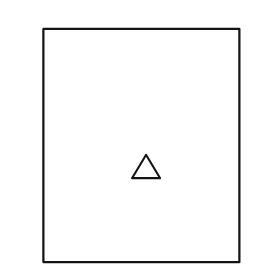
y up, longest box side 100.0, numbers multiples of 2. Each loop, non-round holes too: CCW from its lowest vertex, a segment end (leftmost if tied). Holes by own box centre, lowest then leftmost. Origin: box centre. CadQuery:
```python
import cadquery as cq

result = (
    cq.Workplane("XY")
    .moveTo(-42.0, -50.0)
    .lineTo(42.0, -50.0)
    .lineTo(42.0, 50.0)
    .lineTo(-42.0, 50.0)
    .close()
    .moveTo(-4.0, -14.0)
    .lineTo(8.0, -14.0)
    .lineTo(2.0, -4.0)
    .close()
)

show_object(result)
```